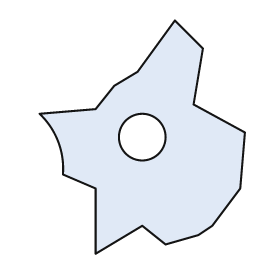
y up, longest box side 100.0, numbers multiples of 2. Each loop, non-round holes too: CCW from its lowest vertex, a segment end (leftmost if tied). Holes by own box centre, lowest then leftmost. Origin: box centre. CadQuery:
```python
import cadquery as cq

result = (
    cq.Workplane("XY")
    .moveTo(-20.0, -50.0)
    .lineTo(0.0, -38.0)
    .lineTo(10.0, -46.0)
    .lineTo(24.0, -42.0)
    .lineTo(30.0, -38.0)
    .lineTo(42.0, -22.0)
    .lineTo(44.0, 2.0)
    .lineTo(22.0, 14.0)
    .lineTo(26.0, 38.0)
    .lineTo(14.0, 50.0)
    .lineTo(-2.0, 28.0)
    .lineTo(-12.0, 22.0)
    .lineTo(-20.0, 12.0)
    .lineTo(-44.0, 10.0)
    .threePointArc((-36.0, -2.0), (-34.0, -16.0))
    .lineTo(-20.0, -22.0)
    .close()
    .moveTo(0.0, 0.0)
    .circle(10.0)
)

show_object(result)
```